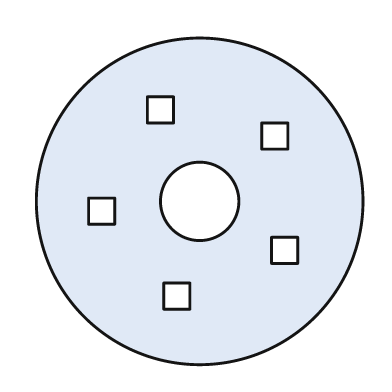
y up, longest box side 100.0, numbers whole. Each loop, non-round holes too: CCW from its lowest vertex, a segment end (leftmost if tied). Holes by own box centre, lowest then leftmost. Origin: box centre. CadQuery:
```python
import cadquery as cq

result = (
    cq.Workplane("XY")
    .moveTo(0.0, 0.0)
    .circle(50.0)
    .moveTo(-11.0, -33.0)
    .lineTo(-3.0, -33.0)
    .lineTo(-3.0, -25.0)
    .lineTo(-11.0, -25.0)
    .close()
    .moveTo(22.0, -19.0)
    .lineTo(30.0, -19.0)
    .lineTo(30.0, -11.0)
    .lineTo(22.0, -11.0)
    .close()
    .moveTo(-34.0, -7.0)
    .lineTo(-26.0, -7.0)
    .lineTo(-26.0, 1.0)
    .lineTo(-34.0, 1.0)
    .close()
    .moveTo(0.0, 0.0)
    .circle(12.0)
    .moveTo(19.0, 16.0)
    .lineTo(27.0, 16.0)
    .lineTo(27.0, 24.0)
    .lineTo(19.0, 24.0)
    .close()
    .moveTo(-16.0, 24.0)
    .lineTo(-8.0, 24.0)
    .lineTo(-8.0, 32.0)
    .lineTo(-16.0, 32.0)
    .close()
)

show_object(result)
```